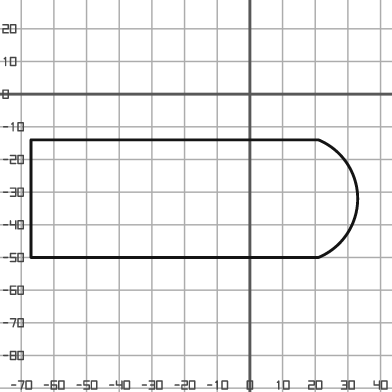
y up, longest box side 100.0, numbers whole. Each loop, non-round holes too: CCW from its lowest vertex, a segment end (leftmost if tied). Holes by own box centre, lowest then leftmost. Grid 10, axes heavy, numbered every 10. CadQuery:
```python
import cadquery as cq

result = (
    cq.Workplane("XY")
    .moveTo(-67.0, -50.0)
    .lineTo(21.0, -50.0)
    .threePointArc((33.0, -32.0), (21.0, -14.0))
    .lineTo(-67.0, -14.0)
    .close()
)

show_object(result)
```